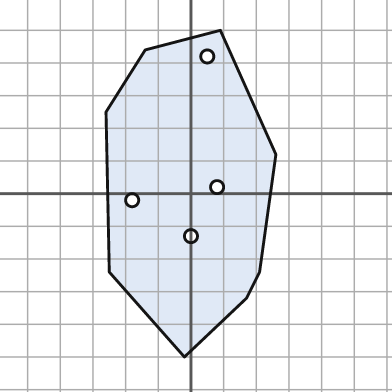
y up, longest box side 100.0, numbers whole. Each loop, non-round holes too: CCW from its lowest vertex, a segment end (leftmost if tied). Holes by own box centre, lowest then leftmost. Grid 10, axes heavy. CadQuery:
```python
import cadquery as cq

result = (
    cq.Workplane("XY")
    .moveTo(-2.0, -50.0)
    .lineTo(17.0, -32.0)
    .lineTo(21.0, -24.0)
    .lineTo(26.0, 12.0)
    .lineTo(9.0, 50.0)
    .lineTo(-14.0, 44.0)
    .lineTo(-26.0, 25.0)
    .lineTo(-25.0, -24.0)
    .close()
    .moveTo(0.0, -13.0)
    .circle(2.0)
    .moveTo(-18.0, -2.0)
    .circle(2.0)
    .moveTo(8.0, 2.0)
    .circle(2.0)
    .moveTo(5.0, 42.0)
    .circle(2.0)
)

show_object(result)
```